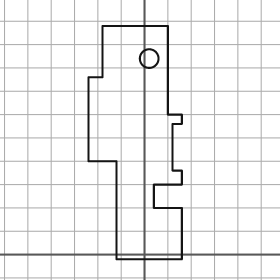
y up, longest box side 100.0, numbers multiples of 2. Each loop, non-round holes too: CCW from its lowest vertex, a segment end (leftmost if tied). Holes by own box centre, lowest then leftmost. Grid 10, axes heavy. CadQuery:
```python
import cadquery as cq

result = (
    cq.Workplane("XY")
    .moveTo(-12.0, -2.0)
    .lineTo(16.0, -2.0)
    .lineTo(16.0, 20.0)
    .lineTo(4.0, 20.0)
    .lineTo(4.0, 30.0)
    .lineTo(16.0, 30.0)
    .lineTo(16.0, 36.0)
    .lineTo(12.0, 36.0)
    .lineTo(12.0, 56.0)
    .lineTo(16.0, 56.0)
    .lineTo(16.0, 60.0)
    .lineTo(10.0, 60.0)
    .lineTo(10.0, 98.0)
    .lineTo(-18.0, 98.0)
    .lineTo(-18.0, 76.0)
    .lineTo(-24.0, 76.0)
    .lineTo(-24.0, 40.0)
    .lineTo(-12.0, 40.0)
    .close()
    .moveTo(2.0, 84.0)
    .circle(4.0)
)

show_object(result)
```